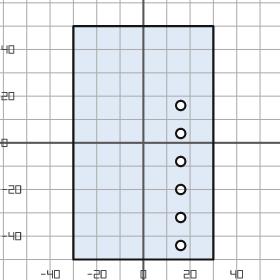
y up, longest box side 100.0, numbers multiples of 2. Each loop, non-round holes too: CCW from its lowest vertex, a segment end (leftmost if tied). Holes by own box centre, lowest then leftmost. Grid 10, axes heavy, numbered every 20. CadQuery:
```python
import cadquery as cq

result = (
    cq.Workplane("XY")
    .moveTo(-30.0, -50.0)
    .lineTo(30.0, -50.0)
    .lineTo(30.0, 50.0)
    .lineTo(-30.0, 50.0)
    .close()
    .moveTo(16.0, -44.0)
    .circle(2.0)
    .moveTo(16.0, -32.0)
    .circle(2.0)
    .moveTo(16.0, -20.0)
    .circle(2.0)
    .moveTo(16.0, -8.0)
    .circle(2.0)
    .moveTo(16.0, 4.0)
    .circle(2.0)
    .moveTo(16.0, 16.0)
    .circle(2.0)
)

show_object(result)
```